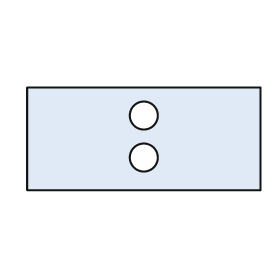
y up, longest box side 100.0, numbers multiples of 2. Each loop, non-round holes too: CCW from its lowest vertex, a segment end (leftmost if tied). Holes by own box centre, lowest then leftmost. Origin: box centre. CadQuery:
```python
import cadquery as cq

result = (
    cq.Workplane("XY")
    .moveTo(-50.0, -22.0)
    .lineTo(50.0, -22.0)
    .lineTo(50.0, 22.0)
    .lineTo(-50.0, 22.0)
    .close()
    .moveTo(0.0, -8.0)
    .circle(6.0)
    .moveTo(0.0, 10.0)
    .circle(6.0)
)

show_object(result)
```